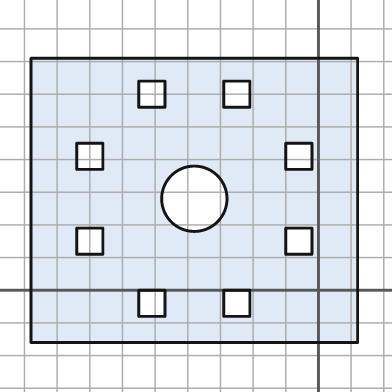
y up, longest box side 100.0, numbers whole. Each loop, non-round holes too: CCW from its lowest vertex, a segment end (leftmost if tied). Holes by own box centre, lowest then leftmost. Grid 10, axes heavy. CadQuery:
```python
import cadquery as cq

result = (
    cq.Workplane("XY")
    .moveTo(-88.0, -16.0)
    .lineTo(12.0, -16.0)
    .lineTo(12.0, 71.0)
    .lineTo(-88.0, 71.0)
    .close()
    .moveTo(-55.0, -8.0)
    .lineTo(-47.0, -8.0)
    .lineTo(-47.0, 0.0)
    .lineTo(-55.0, 0.0)
    .close()
    .moveTo(-29.0, -8.0)
    .lineTo(-21.0, -8.0)
    .lineTo(-21.0, 0.0)
    .lineTo(-29.0, 0.0)
    .close()
    .moveTo(-74.0, 11.0)
    .lineTo(-66.0, 11.0)
    .lineTo(-66.0, 19.0)
    .lineTo(-74.0, 19.0)
    .close()
    .moveTo(-10.0, 11.0)
    .lineTo(-2.0, 11.0)
    .lineTo(-2.0, 19.0)
    .lineTo(-10.0, 19.0)
    .close()
    .moveTo(-38.0, 28.0)
    .circle(10.0)
    .moveTo(-74.0, 37.0)
    .lineTo(-66.0, 37.0)
    .lineTo(-66.0, 45.0)
    .lineTo(-74.0, 45.0)
    .close()
    .moveTo(-10.0, 37.0)
    .lineTo(-2.0, 37.0)
    .lineTo(-2.0, 45.0)
    .lineTo(-10.0, 45.0)
    .close()
    .moveTo(-55.0, 56.0)
    .lineTo(-47.0, 56.0)
    .lineTo(-47.0, 64.0)
    .lineTo(-55.0, 64.0)
    .close()
    .moveTo(-29.0, 56.0)
    .lineTo(-21.0, 56.0)
    .lineTo(-21.0, 64.0)
    .lineTo(-29.0, 64.0)
    .close()
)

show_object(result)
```